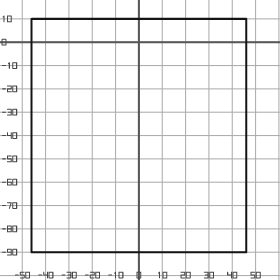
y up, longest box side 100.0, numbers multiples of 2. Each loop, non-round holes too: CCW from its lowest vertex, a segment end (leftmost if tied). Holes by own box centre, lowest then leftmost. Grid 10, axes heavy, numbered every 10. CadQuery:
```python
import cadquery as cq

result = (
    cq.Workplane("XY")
    .moveTo(-46.0, -90.0)
    .lineTo(46.0, -90.0)
    .lineTo(46.0, 10.0)
    .lineTo(-46.0, 10.0)
    .close()
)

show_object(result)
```